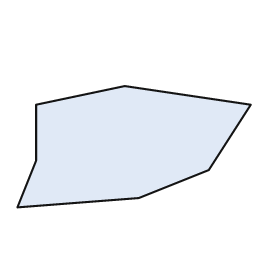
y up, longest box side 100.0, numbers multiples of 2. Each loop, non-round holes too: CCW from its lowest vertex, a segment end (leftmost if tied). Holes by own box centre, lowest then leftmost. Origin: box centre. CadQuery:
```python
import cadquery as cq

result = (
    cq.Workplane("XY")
    .moveTo(-50.0, -26.0)
    .lineTo(2.0, -22.0)
    .lineTo(32.0, -10.0)
    .lineTo(50.0, 18.0)
    .lineTo(-4.0, 26.0)
    .lineTo(-42.0, 18.0)
    .lineTo(-42.0, -6.0)
    .close()
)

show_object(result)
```